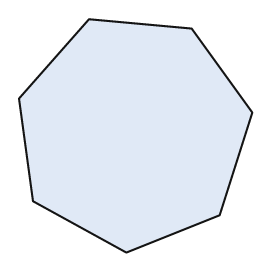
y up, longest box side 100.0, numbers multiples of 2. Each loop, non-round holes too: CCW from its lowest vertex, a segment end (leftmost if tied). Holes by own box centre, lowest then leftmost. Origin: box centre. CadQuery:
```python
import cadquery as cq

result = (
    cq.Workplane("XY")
    .moveTo(-4.0, -50.0)
    .lineTo(36.0, -34.0)
    .lineTo(50.0, 10.0)
    .lineTo(24.0, 46.0)
    .lineTo(-20.0, 50.0)
    .lineTo(-50.0, 16.0)
    .lineTo(-44.0, -28.0)
    .close()
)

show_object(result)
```